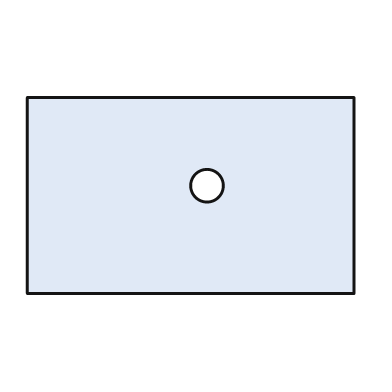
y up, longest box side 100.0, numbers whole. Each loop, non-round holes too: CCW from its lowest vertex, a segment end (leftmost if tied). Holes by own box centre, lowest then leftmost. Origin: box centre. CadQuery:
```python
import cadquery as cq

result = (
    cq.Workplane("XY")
    .moveTo(-50.0, -30.0)
    .lineTo(50.0, -30.0)
    .lineTo(50.0, 30.0)
    .lineTo(-50.0, 30.0)
    .close()
    .moveTo(5.0, 3.0)
    .circle(5.0)
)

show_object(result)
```